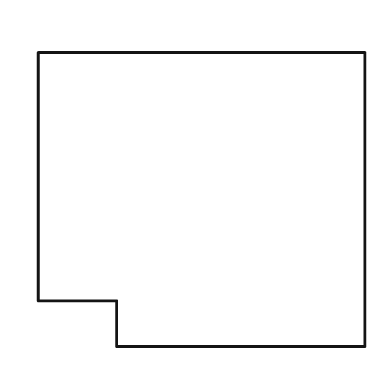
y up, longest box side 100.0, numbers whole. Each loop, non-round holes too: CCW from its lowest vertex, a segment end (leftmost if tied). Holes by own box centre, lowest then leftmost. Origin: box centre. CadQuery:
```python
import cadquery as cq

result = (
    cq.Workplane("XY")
    .moveTo(-26.0, -45.0)
    .lineTo(50.0, -45.0)
    .lineTo(50.0, 45.0)
    .lineTo(-50.0, 45.0)
    .lineTo(-50.0, -31.0)
    .lineTo(-26.0, -31.0)
    .close()
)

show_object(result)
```